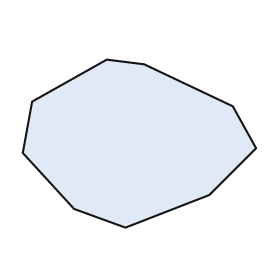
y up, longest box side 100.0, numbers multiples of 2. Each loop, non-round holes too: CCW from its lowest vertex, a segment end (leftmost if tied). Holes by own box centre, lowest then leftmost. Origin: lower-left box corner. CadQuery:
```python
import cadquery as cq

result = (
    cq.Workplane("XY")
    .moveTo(44.0, 0.0)
    .lineTo(80.0, 14.0)
    .lineTo(100.0, 34.0)
    .lineTo(90.0, 52.0)
    .lineTo(52.0, 70.0)
    .lineTo(36.0, 72.0)
    .lineTo(4.0, 54.0)
    .lineTo(0.0, 32.0)
    .lineTo(22.0, 8.0)
    .close()
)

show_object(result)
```